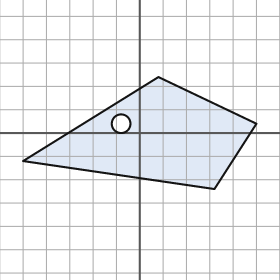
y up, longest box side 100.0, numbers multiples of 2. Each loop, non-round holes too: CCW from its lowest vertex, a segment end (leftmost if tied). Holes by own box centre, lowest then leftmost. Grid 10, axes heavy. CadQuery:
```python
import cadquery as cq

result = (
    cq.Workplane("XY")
    .moveTo(32.0, -24.0)
    .lineTo(50.0, 4.0)
    .lineTo(8.0, 24.0)
    .lineTo(-50.0, -12.0)
    .close()
    .moveTo(-8.0, 4.0)
    .circle(4.0)
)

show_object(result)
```